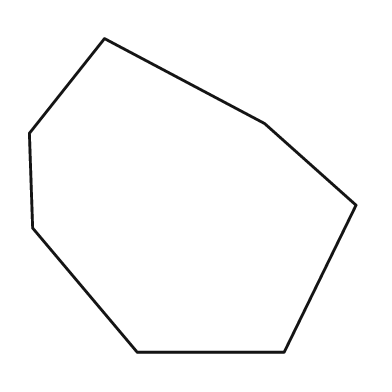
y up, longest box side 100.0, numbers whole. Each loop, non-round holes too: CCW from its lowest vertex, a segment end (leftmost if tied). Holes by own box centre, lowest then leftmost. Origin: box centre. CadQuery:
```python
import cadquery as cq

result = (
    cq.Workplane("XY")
    .moveTo(-17.0, -48.0)
    .lineTo(28.0, -48.0)
    .lineTo(50.0, -3.0)
    .lineTo(22.0, 22.0)
    .lineTo(-27.0, 48.0)
    .lineTo(-50.0, 19.0)
    .lineTo(-49.0, -10.0)
    .close()
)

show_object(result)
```